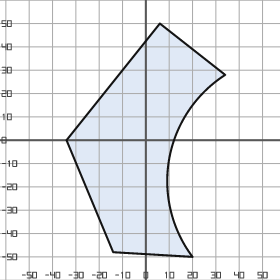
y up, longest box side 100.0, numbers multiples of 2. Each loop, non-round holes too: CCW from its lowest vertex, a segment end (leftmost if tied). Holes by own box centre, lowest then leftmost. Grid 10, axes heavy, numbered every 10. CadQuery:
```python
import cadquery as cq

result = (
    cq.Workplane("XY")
    .moveTo(20.0, -50.0)
    .threePointArc((10.0, -8.0), (34.0, 28.0))
    .lineTo(6.0, 50.0)
    .lineTo(-34.0, 0.0)
    .lineTo(-14.0, -48.0)
    .close()
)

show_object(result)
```